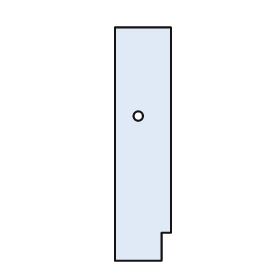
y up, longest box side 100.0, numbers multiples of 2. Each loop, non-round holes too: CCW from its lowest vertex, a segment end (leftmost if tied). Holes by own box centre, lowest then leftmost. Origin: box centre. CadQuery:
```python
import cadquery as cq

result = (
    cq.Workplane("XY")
    .moveTo(-12.0, -50.0)
    .lineTo(8.0, -50.0)
    .lineTo(8.0, -38.0)
    .lineTo(12.0, -38.0)
    .lineTo(12.0, 50.0)
    .lineTo(-12.0, 50.0)
    .close()
    .moveTo(-2.0, 12.0)
    .circle(2.0)
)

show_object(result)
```